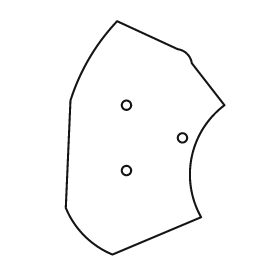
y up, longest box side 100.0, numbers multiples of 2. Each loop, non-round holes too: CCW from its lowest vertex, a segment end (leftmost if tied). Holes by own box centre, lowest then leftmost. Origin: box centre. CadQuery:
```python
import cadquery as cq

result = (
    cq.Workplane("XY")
    .moveTo(-14.0, -50.0)
    .lineTo(24.0, -34.0)
    .threePointArc((20.0, -8.0), (34.0, 14.0))
    .lineTo(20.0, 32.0)
    .threePointArc((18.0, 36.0), (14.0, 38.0))
    .lineTo(-12.0, 50.0)
    .threePointArc((-24.0, 34.0), (-32.0, 16.0))
    .lineTo(-34.0, -30.0)
    .threePointArc((-26.0, -42.0), (-14.0, -50.0))
    .close()
    .moveTo(-8.0, -14.0)
    .circle(2.0)
    .moveTo(16.0, 0.0)
    .circle(2.0)
    .moveTo(-8.0, 14.0)
    .circle(2.0)
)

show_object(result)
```